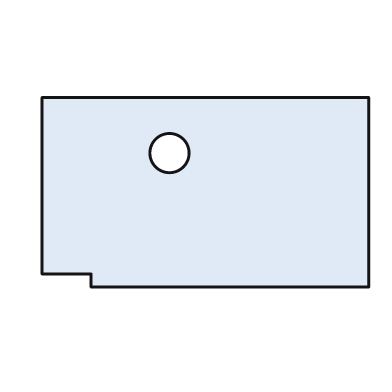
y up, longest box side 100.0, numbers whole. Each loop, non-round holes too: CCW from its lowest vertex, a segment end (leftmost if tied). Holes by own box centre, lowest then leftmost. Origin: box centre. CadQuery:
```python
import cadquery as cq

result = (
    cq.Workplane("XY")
    .moveTo(-35.0, -29.0)
    .lineTo(50.0, -29.0)
    .lineTo(50.0, 29.0)
    .lineTo(-50.0, 29.0)
    .lineTo(-50.0, -25.0)
    .lineTo(-35.0, -25.0)
    .close()
    .moveTo(-11.0, 12.0)
    .circle(6.0)
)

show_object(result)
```